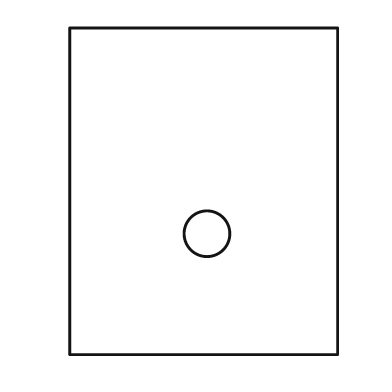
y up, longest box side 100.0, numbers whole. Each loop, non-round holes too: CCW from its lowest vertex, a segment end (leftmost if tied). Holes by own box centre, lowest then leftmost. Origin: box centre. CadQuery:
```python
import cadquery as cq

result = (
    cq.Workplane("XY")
    .moveTo(-41.0, -50.0)
    .lineTo(41.0, -50.0)
    .lineTo(41.0, 50.0)
    .lineTo(-41.0, 50.0)
    .close()
    .moveTo(1.0, -13.0)
    .circle(7.0)
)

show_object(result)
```